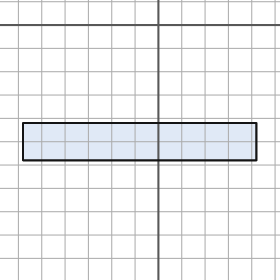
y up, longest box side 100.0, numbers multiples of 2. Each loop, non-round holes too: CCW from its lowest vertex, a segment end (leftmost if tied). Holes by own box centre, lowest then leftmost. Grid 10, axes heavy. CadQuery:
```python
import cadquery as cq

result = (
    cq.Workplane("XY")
    .moveTo(-58.0, -58.0)
    .lineTo(42.0, -58.0)
    .lineTo(42.0, -42.0)
    .lineTo(-58.0, -42.0)
    .close()
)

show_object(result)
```